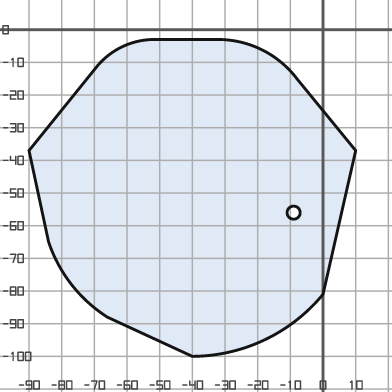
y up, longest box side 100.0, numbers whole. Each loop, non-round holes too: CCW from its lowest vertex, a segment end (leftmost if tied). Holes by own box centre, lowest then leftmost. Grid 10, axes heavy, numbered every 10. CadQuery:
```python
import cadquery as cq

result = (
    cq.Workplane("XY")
    .moveTo(-40.0, -100.0)
    .threePointArc((-18.0, -95.0), (0.0, -81.0))
    .lineTo(10.0, -37.0)
    .lineTo(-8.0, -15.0)
    .threePointArc((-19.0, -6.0), (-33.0, -3.0))
    .lineTo(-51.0, -3.0)
    .threePointArc((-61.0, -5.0), (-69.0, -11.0))
    .lineTo(-90.0, -37.0)
    .lineTo(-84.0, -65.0)
    .threePointArc((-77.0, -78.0), (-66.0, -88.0))
    .close()
    .moveTo(-9.0, -56.0)
    .circle(2.0)
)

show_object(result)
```